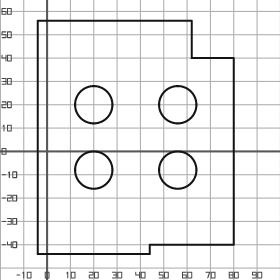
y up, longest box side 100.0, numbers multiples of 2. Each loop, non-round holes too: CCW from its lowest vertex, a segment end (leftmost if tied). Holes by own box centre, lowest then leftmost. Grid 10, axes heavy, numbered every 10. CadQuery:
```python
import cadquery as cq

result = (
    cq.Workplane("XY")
    .moveTo(-4.0, -44.0)
    .lineTo(44.0, -44.0)
    .lineTo(44.0, -40.0)
    .lineTo(80.0, -40.0)
    .lineTo(80.0, 40.0)
    .lineTo(62.0, 40.0)
    .lineTo(62.0, 56.0)
    .lineTo(-4.0, 56.0)
    .close()
    .moveTo(20.0, -8.0)
    .circle(8.0)
    .moveTo(56.0, -8.0)
    .circle(8.0)
    .moveTo(20.0, 20.0)
    .circle(8.0)
    .moveTo(56.0, 20.0)
    .circle(8.0)
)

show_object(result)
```